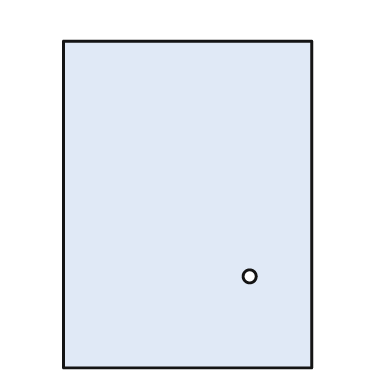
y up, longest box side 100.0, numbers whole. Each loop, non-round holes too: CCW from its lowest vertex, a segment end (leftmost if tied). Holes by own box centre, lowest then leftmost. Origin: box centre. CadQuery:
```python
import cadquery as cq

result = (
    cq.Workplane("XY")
    .moveTo(-38.0, -50.0)
    .lineTo(38.0, -50.0)
    .lineTo(38.0, 50.0)
    .lineTo(-38.0, 50.0)
    .close()
    .moveTo(19.0, -22.0)
    .circle(2.0)
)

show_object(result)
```